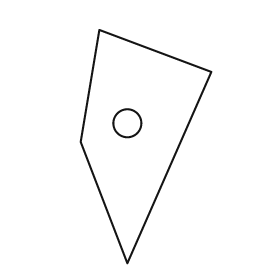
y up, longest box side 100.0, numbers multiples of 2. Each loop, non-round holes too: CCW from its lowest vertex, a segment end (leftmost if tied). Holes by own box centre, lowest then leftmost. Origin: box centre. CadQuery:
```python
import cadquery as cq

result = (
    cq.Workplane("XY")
    .moveTo(-8.0, -50.0)
    .lineTo(28.0, 32.0)
    .lineTo(-20.0, 50.0)
    .lineTo(-28.0, 2.0)
    .close()
    .moveTo(-8.0, 10.0)
    .circle(6.0)
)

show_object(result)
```